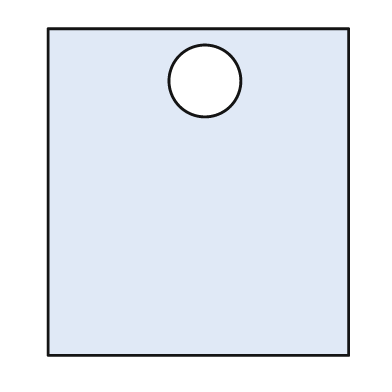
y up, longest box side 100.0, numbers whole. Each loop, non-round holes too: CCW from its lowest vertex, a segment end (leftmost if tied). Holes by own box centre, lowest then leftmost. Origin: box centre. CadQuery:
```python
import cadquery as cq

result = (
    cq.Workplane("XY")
    .moveTo(-46.0, -50.0)
    .lineTo(46.0, -50.0)
    .lineTo(46.0, 50.0)
    .lineTo(-46.0, 50.0)
    .close()
    .moveTo(2.0, 34.0)
    .circle(11.0)
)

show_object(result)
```